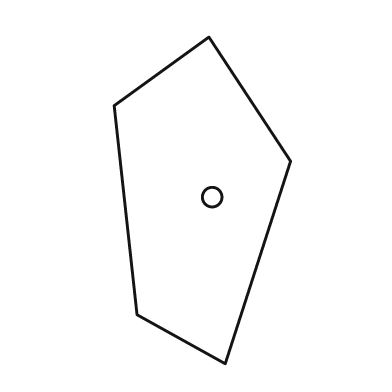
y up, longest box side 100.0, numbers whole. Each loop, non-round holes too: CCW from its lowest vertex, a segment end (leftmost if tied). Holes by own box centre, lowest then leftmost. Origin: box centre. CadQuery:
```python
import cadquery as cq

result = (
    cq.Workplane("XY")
    .moveTo(7.0, -50.0)
    .lineTo(27.0, 12.0)
    .lineTo(2.0, 50.0)
    .lineTo(-27.0, 29.0)
    .lineTo(-20.0, -35.0)
    .close()
    .moveTo(3.0, 1.0)
    .circle(3.0)
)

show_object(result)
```